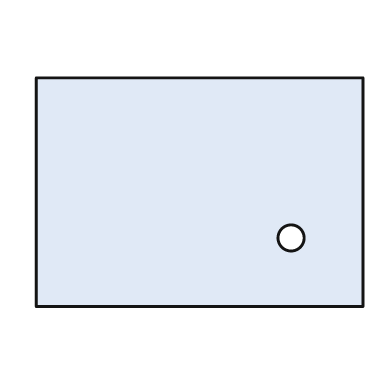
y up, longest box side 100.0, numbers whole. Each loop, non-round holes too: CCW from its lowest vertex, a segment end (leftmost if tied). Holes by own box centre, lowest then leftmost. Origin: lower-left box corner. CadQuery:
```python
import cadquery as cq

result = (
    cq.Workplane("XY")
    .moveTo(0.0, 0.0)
    .lineTo(100.0, 0.0)
    .lineTo(100.0, 70.0)
    .lineTo(0.0, 70.0)
    .close()
    .moveTo(78.0, 21.0)
    .circle(4.0)
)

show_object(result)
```